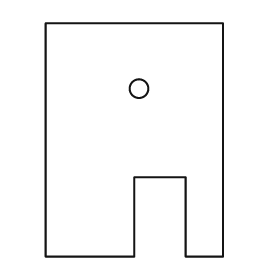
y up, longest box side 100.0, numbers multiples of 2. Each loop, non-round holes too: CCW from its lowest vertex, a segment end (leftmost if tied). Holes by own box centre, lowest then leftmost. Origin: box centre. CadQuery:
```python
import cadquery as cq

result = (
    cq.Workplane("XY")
    .moveTo(-38.0, -50.0)
    .lineTo(0.0, -50.0)
    .lineTo(0.0, -16.0)
    .lineTo(22.0, -16.0)
    .lineTo(22.0, -50.0)
    .lineTo(38.0, -50.0)
    .lineTo(38.0, 50.0)
    .lineTo(-38.0, 50.0)
    .close()
    .moveTo(2.0, 22.0)
    .circle(4.0)
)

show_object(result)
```